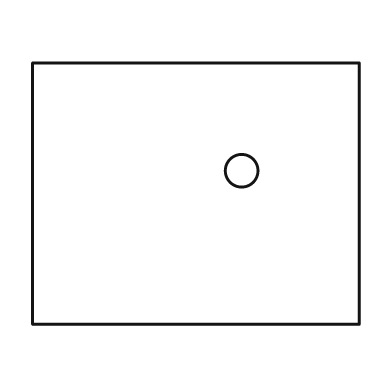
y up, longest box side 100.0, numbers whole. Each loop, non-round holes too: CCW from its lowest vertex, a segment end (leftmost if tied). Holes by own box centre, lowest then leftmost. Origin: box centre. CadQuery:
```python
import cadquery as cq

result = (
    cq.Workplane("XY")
    .moveTo(-50.0, -40.0)
    .lineTo(50.0, -40.0)
    .lineTo(50.0, 40.0)
    .lineTo(-50.0, 40.0)
    .close()
    .moveTo(14.0, 7.0)
    .circle(5.0)
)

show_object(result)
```